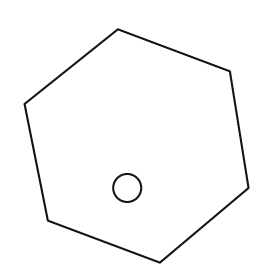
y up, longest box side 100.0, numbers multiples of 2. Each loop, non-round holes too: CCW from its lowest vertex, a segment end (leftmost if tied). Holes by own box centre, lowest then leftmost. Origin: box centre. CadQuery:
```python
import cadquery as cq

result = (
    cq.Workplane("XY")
    .moveTo(10.0, -50.0)
    .lineTo(48.0, -18.0)
    .lineTo(40.0, 32.0)
    .lineTo(-8.0, 50.0)
    .lineTo(-48.0, 18.0)
    .lineTo(-38.0, -32.0)
    .close()
    .moveTo(-4.0, -18.0)
    .circle(6.0)
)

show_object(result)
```